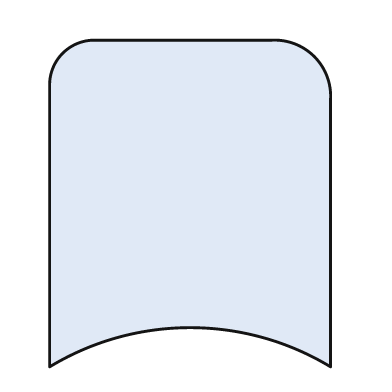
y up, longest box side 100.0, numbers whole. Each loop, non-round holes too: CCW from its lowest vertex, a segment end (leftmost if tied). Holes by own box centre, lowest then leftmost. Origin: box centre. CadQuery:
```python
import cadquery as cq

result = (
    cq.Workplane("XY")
    .moveTo(-43.0, -50.0)
    .threePointArc((0.0, -38.0), (43.0, -50.0))
    .lineTo(43.0, 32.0)
    .threePointArc((38.0, 45.0), (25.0, 50.0))
    .lineTo(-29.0, 50.0)
    .threePointArc((-39.0, 46.0), (-43.0, 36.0))
    .close()
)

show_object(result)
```